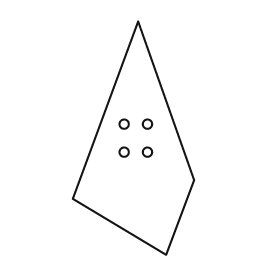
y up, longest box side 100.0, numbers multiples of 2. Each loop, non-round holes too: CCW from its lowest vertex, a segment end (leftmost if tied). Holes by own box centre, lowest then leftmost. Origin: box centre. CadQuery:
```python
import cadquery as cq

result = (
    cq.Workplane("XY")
    .moveTo(14.0, -50.0)
    .lineTo(26.0, -18.0)
    .lineTo(2.0, 50.0)
    .lineTo(-26.0, -26.0)
    .close()
    .moveTo(-4.0, -6.0)
    .circle(2.0)
    .moveTo(6.0, -6.0)
    .circle(2.0)
    .moveTo(-4.0, 6.0)
    .circle(2.0)
    .moveTo(6.0, 6.0)
    .circle(2.0)
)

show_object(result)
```